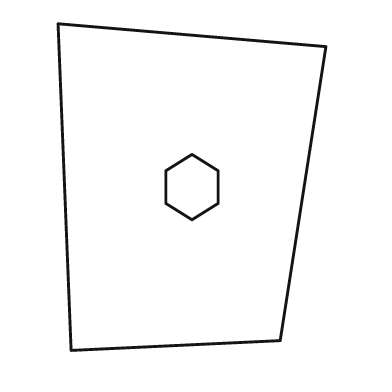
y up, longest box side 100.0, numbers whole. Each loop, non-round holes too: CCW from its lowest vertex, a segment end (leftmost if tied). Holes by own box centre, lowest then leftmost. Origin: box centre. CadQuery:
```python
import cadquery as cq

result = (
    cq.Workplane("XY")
    .moveTo(-37.0, -50.0)
    .lineTo(27.0, -47.0)
    .lineTo(41.0, 43.0)
    .lineTo(-41.0, 50.0)
    .close()
    .moveTo(0.0, -10.0)
    .lineTo(8.0, -5.0)
    .lineTo(8.0, 5.0)
    .lineTo(0.0, 10.0)
    .lineTo(-8.0, 5.0)
    .lineTo(-8.0, -5.0)
    .close()
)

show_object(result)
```